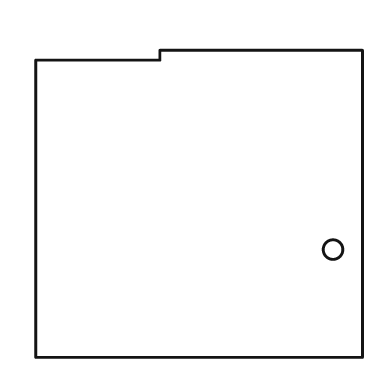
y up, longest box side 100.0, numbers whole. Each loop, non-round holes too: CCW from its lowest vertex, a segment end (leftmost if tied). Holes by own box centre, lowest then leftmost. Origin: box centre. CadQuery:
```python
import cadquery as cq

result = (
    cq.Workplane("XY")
    .moveTo(-50.0, -47.0)
    .lineTo(50.0, -47.0)
    .lineTo(50.0, 47.0)
    .lineTo(-12.0, 47.0)
    .lineTo(-12.0, 44.0)
    .lineTo(-50.0, 44.0)
    .close()
    .moveTo(41.0, -14.0)
    .circle(3.0)
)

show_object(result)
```